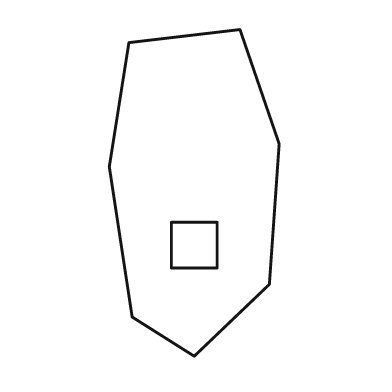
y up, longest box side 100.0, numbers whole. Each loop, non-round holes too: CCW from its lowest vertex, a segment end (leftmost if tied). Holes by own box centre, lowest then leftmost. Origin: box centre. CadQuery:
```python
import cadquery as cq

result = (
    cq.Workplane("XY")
    .moveTo(0.0, -50.0)
    .lineTo(23.0, -28.0)
    .lineTo(26.0, 15.0)
    .lineTo(14.0, 50.0)
    .lineTo(-20.0, 46.0)
    .lineTo(-26.0, 8.0)
    .lineTo(-19.0, -38.0)
    .close()
    .moveTo(-7.0, -23.0)
    .lineTo(7.0, -23.0)
    .lineTo(7.0, -9.0)
    .lineTo(-7.0, -9.0)
    .close()
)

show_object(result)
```